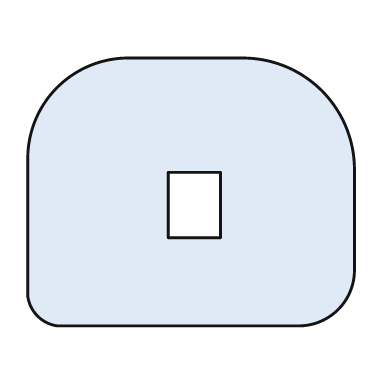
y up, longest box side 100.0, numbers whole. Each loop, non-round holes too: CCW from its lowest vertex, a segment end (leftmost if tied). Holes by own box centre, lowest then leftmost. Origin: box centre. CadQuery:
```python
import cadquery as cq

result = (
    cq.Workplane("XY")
    .moveTo(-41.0, -41.0)
    .lineTo(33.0, -41.0)
    .threePointArc((45.0, -36.0), (50.0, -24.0))
    .lineTo(50.0, 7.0)
    .threePointArc((40.0, 31.0), (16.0, 41.0))
    .lineTo(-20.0, 41.0)
    .threePointArc((-41.0, 32.0), (-50.0, 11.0))
    .lineTo(-50.0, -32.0)
    .threePointArc((-47.0, -38.0), (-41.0, -41.0))
    .close()
    .moveTo(-7.0, -14.0)
    .lineTo(9.0, -14.0)
    .lineTo(9.0, 6.0)
    .lineTo(-7.0, 6.0)
    .close()
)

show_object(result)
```